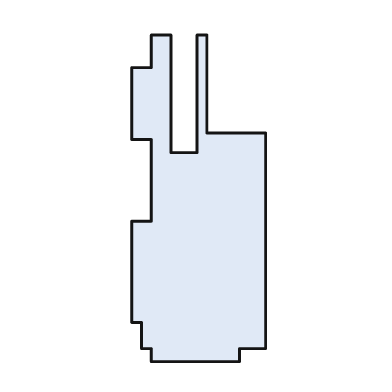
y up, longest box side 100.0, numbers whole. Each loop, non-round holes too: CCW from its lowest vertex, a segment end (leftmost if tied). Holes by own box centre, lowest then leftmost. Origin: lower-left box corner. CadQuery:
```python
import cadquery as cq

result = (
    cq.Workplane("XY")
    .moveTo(6.0, 0.0)
    .lineTo(33.0, 0.0)
    .lineTo(33.0, 4.0)
    .lineTo(41.0, 4.0)
    .lineTo(41.0, 70.0)
    .lineTo(23.0, 70.0)
    .lineTo(23.0, 100.0)
    .lineTo(20.0, 100.0)
    .lineTo(20.0, 64.0)
    .lineTo(12.0, 64.0)
    .lineTo(12.0, 100.0)
    .lineTo(6.0, 100.0)
    .lineTo(6.0, 90.0)
    .lineTo(0.0, 90.0)
    .lineTo(0.0, 68.0)
    .lineTo(6.0, 68.0)
    .lineTo(6.0, 43.0)
    .lineTo(0.0, 43.0)
    .lineTo(0.0, 12.0)
    .lineTo(3.0, 12.0)
    .lineTo(3.0, 4.0)
    .lineTo(6.0, 4.0)
    .close()
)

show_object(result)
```